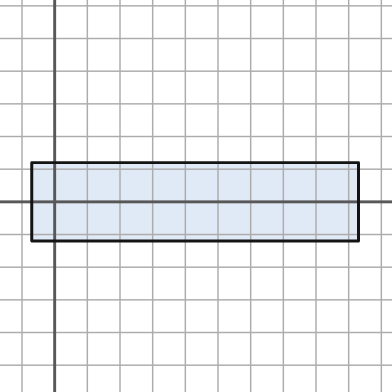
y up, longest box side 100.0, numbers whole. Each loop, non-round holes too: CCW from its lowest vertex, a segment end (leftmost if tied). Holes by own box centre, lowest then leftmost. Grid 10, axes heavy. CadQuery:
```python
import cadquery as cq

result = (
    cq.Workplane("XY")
    .moveTo(-7.0, -12.0)
    .lineTo(93.0, -12.0)
    .lineTo(93.0, 12.0)
    .lineTo(-7.0, 12.0)
    .close()
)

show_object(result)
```